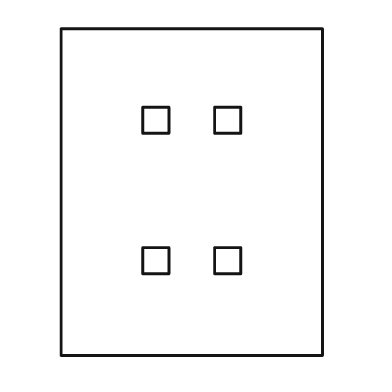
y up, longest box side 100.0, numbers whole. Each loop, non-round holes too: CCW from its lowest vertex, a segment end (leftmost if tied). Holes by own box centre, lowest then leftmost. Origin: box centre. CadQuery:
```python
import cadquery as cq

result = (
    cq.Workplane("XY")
    .moveTo(-40.0, -50.0)
    .lineTo(40.0, -50.0)
    .lineTo(40.0, 50.0)
    .lineTo(-40.0, 50.0)
    .close()
    .moveTo(-15.0, -25.0)
    .lineTo(-7.0, -25.0)
    .lineTo(-7.0, -17.0)
    .lineTo(-15.0, -17.0)
    .close()
    .moveTo(7.0, -25.0)
    .lineTo(15.0, -25.0)
    .lineTo(15.0, -17.0)
    .lineTo(7.0, -17.0)
    .close()
    .moveTo(-15.0, 18.0)
    .lineTo(-7.0, 18.0)
    .lineTo(-7.0, 26.0)
    .lineTo(-15.0, 26.0)
    .close()
    .moveTo(7.0, 18.0)
    .lineTo(15.0, 18.0)
    .lineTo(15.0, 26.0)
    .lineTo(7.0, 26.0)
    .close()
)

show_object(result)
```